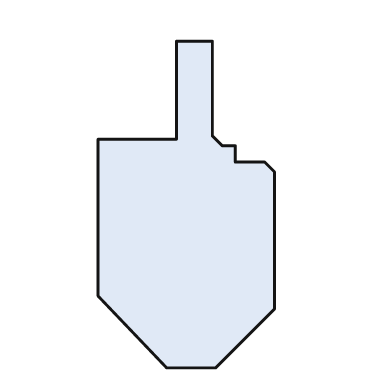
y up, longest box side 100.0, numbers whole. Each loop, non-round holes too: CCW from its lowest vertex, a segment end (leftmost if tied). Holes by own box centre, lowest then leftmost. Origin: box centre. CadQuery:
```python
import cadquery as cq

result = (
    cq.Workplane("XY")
    .moveTo(-6.0, -50.0)
    .lineTo(9.0, -50.0)
    .lineTo(27.0, -32.0)
    .lineTo(27.0, 10.0)
    .lineTo(24.0, 13.0)
    .lineTo(15.0, 13.0)
    .lineTo(15.0, 18.0)
    .lineTo(11.0, 18.0)
    .lineTo(8.0, 21.0)
    .lineTo(8.0, 50.0)
    .lineTo(-3.0, 50.0)
    .lineTo(-3.0, 20.0)
    .lineTo(-27.0, 20.0)
    .lineTo(-27.0, -28.0)
    .close()
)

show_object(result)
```